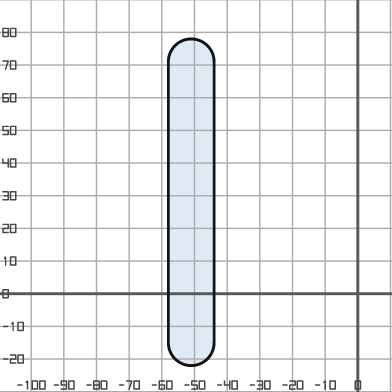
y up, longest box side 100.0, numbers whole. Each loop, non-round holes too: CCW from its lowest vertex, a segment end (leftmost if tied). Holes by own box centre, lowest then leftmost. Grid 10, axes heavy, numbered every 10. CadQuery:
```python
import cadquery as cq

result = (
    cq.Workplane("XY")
    .moveTo(-58.0, -15.0)
    .threePointArc((-51.0, -22.0), (-44.0, -15.0))
    .lineTo(-44.0, 71.0)
    .threePointArc((-51.0, 78.0), (-58.0, 71.0))
    .close()
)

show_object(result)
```